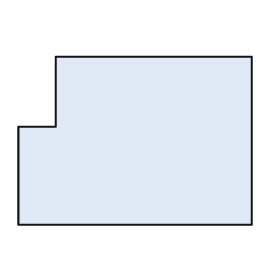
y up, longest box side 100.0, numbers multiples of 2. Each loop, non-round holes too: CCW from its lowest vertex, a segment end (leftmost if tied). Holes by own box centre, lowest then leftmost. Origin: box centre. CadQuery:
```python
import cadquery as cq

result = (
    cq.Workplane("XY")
    .moveTo(-50.0, -36.0)
    .lineTo(50.0, -36.0)
    .lineTo(50.0, 36.0)
    .lineTo(-34.0, 36.0)
    .lineTo(-34.0, 6.0)
    .lineTo(-50.0, 6.0)
    .close()
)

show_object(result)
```